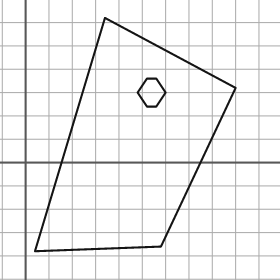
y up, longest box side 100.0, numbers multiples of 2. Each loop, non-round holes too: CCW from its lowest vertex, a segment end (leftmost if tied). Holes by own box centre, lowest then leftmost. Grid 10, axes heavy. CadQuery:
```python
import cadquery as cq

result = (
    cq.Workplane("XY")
    .moveTo(4.0, -38.0)
    .lineTo(58.0, -36.0)
    .lineTo(90.0, 32.0)
    .lineTo(34.0, 62.0)
    .close()
    .moveTo(52.0, 24.0)
    .lineTo(56.0, 24.0)
    .lineTo(60.0, 30.0)
    .lineTo(56.0, 36.0)
    .lineTo(52.0, 36.0)
    .lineTo(48.0, 30.0)
    .close()
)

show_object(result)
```